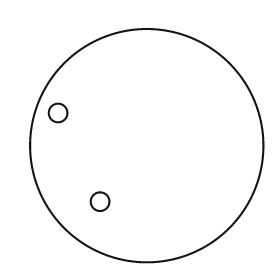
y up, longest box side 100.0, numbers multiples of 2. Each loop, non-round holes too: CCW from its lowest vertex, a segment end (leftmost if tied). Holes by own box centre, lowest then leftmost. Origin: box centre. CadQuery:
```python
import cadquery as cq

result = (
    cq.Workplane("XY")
    .moveTo(0.0, 0.0)
    .circle(50.0)
    .moveTo(-20.0, -24.0)
    .circle(4.0)
    .moveTo(-38.0, 14.0)
    .circle(4.0)
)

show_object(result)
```